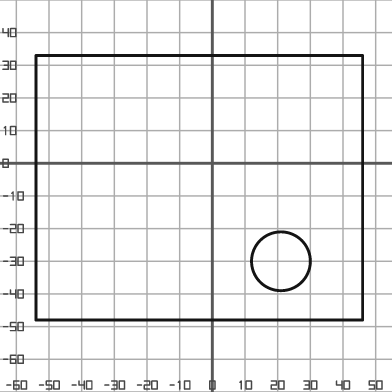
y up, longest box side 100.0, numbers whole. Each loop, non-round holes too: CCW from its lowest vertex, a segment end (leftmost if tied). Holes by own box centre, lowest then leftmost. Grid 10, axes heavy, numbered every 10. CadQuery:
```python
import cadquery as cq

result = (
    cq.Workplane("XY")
    .moveTo(-54.0, -48.0)
    .lineTo(46.0, -48.0)
    .lineTo(46.0, 33.0)
    .lineTo(-54.0, 33.0)
    .close()
    .moveTo(21.0, -30.0)
    .circle(9.0)
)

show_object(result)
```